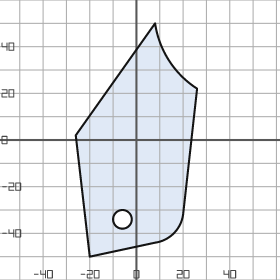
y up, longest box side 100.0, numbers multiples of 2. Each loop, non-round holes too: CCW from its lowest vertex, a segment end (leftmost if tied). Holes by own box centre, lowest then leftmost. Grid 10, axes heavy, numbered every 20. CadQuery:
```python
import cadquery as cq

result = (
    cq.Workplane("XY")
    .moveTo(-20.0, -50.0)
    .lineTo(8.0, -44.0)
    .threePointArc((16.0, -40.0), (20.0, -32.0))
    .lineTo(26.0, 22.0)
    .threePointArc((14.0, 34.0), (8.0, 50.0))
    .lineTo(-26.0, 2.0)
    .close()
    .moveTo(-6.0, -34.0)
    .circle(4.0)
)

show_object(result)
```